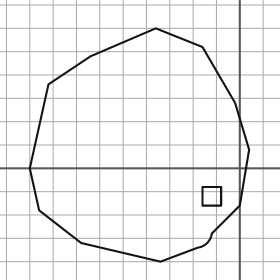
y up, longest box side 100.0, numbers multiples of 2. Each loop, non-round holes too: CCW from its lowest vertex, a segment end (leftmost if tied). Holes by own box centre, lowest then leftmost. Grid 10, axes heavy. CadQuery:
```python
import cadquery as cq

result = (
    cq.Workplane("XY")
    .moveTo(-34.0, -40.0)
    .lineTo(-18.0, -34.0)
    .threePointArc((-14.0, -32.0), (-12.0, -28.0))
    .lineTo(0.0, -16.0)
    .lineTo(4.0, 8.0)
    .lineTo(-2.0, 28.0)
    .lineTo(-16.0, 52.0)
    .lineTo(-36.0, 60.0)
    .lineTo(-64.0, 48.0)
    .lineTo(-82.0, 36.0)
    .lineTo(-90.0, 0.0)
    .lineTo(-86.0, -18.0)
    .lineTo(-68.0, -32.0)
    .close()
    .moveTo(-16.0, -16.0)
    .lineTo(-8.0, -16.0)
    .lineTo(-8.0, -8.0)
    .lineTo(-16.0, -8.0)
    .close()
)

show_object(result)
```